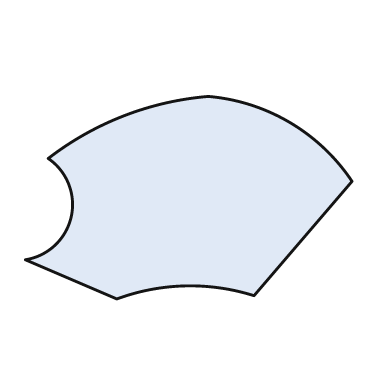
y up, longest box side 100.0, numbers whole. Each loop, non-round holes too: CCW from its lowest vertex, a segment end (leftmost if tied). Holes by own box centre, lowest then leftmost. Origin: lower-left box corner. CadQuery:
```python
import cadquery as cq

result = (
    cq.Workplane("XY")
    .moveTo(28.0, 0.0)
    .threePointArc((49.0, 4.0), (70.0, 1.0))
    .lineTo(100.0, 36.0)
    .threePointArc((81.0, 54.0), (56.0, 62.0))
    .threePointArc((30.0, 56.0), (7.0, 43.0))
    .threePointArc((14.0, 25.0), (0.0, 12.0))
    .close()
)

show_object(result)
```